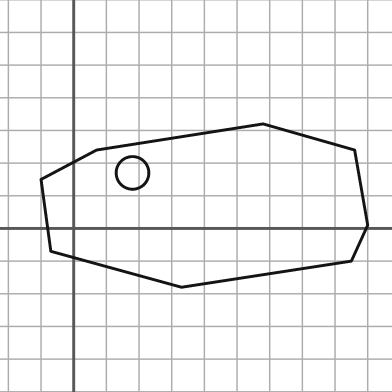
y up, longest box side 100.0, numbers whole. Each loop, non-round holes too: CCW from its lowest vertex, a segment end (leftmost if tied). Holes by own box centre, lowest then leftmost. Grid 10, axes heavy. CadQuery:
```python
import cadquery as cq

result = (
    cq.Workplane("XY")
    .moveTo(33.0, -18.0)
    .lineTo(85.0, -10.0)
    .lineTo(90.0, 1.0)
    .lineTo(86.0, 24.0)
    .lineTo(58.0, 32.0)
    .lineTo(7.0, 24.0)
    .lineTo(-10.0, 15.0)
    .lineTo(-7.0, -7.0)
    .close()
    .moveTo(18.0, 17.0)
    .circle(5.0)
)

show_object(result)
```